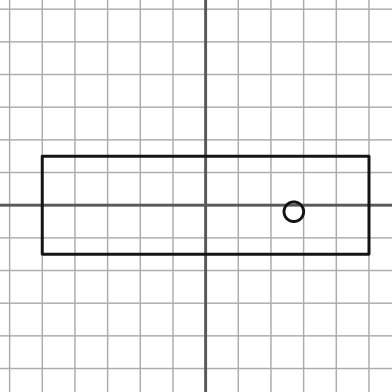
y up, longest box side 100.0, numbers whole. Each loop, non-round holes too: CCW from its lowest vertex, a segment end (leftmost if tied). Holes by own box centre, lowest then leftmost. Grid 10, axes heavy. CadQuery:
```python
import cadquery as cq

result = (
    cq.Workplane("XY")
    .moveTo(-50.0, -15.0)
    .lineTo(50.0, -15.0)
    .lineTo(50.0, 15.0)
    .lineTo(-50.0, 15.0)
    .close()
    .moveTo(27.0, -2.0)
    .circle(3.0)
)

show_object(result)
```